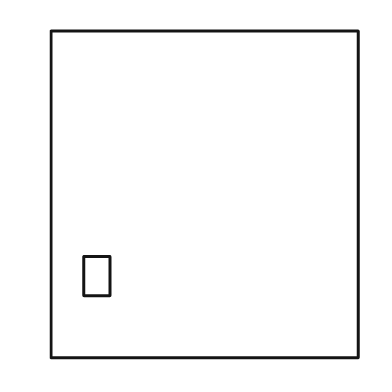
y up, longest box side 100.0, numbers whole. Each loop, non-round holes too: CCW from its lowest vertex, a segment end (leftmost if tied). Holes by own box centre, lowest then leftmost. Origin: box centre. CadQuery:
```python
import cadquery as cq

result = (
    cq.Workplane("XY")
    .moveTo(-47.0, -50.0)
    .lineTo(47.0, -50.0)
    .lineTo(47.0, 50.0)
    .lineTo(-47.0, 50.0)
    .close()
    .moveTo(-37.0, -31.0)
    .lineTo(-29.0, -31.0)
    .lineTo(-29.0, -19.0)
    .lineTo(-37.0, -19.0)
    .close()
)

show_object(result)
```